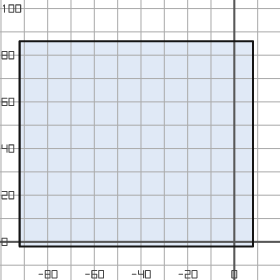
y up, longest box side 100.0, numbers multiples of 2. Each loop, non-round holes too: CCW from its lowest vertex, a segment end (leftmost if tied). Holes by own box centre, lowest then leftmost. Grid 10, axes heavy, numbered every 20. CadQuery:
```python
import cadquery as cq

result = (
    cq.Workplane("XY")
    .moveTo(-92.0, -2.0)
    .lineTo(8.0, -2.0)
    .lineTo(8.0, 86.0)
    .lineTo(-92.0, 86.0)
    .close()
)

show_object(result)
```